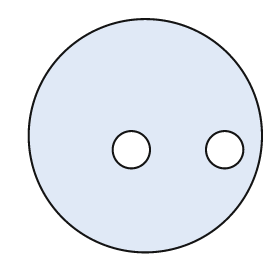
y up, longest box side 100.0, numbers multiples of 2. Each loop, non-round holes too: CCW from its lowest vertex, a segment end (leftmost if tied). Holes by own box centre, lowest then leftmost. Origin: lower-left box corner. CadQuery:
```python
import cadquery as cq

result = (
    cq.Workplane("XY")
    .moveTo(50.0, 50.0)
    .circle(50.0)
    .moveTo(44.0, 44.0)
    .circle(8.0)
    .moveTo(84.0, 44.0)
    .circle(8.0)
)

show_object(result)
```